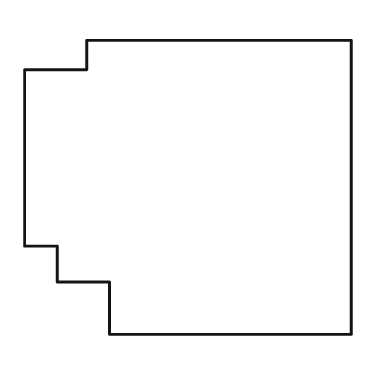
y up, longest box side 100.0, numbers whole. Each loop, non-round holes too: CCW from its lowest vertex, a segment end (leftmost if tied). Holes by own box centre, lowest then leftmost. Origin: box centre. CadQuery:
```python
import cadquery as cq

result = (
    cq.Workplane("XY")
    .moveTo(-24.0, -45.0)
    .lineTo(50.0, -45.0)
    .lineTo(50.0, 45.0)
    .lineTo(-31.0, 45.0)
    .lineTo(-31.0, 36.0)
    .lineTo(-50.0, 36.0)
    .lineTo(-50.0, -18.0)
    .lineTo(-40.0, -18.0)
    .lineTo(-40.0, -29.0)
    .lineTo(-24.0, -29.0)
    .close()
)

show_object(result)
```